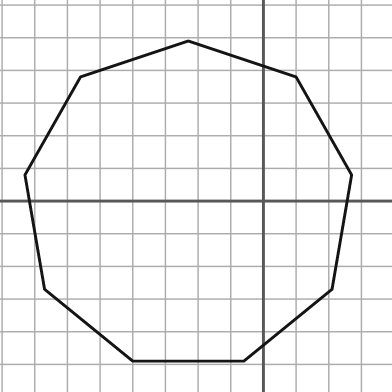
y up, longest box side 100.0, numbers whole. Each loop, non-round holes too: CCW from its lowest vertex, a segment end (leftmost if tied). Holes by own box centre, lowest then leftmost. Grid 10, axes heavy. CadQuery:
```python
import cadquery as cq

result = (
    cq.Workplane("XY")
    .moveTo(-40.0, -49.0)
    .lineTo(-6.0, -49.0)
    .lineTo(21.0, -27.0)
    .lineTo(27.0, 8.0)
    .lineTo(10.0, 38.0)
    .lineTo(-23.0, 49.0)
    .lineTo(-56.0, 38.0)
    .lineTo(-73.0, 8.0)
    .lineTo(-67.0, -27.0)
    .close()
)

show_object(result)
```